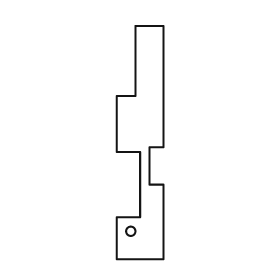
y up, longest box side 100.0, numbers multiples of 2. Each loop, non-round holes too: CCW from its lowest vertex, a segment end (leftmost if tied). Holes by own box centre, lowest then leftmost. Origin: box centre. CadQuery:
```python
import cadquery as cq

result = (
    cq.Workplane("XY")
    .moveTo(-10.0, -50.0)
    .lineTo(10.0, -50.0)
    .lineTo(10.0, -18.0)
    .lineTo(4.0, -18.0)
    .lineTo(4.0, -2.0)
    .lineTo(10.0, -2.0)
    .lineTo(10.0, 50.0)
    .lineTo(-2.0, 50.0)
    .lineTo(-2.0, 20.0)
    .lineTo(-10.0, 20.0)
    .lineTo(-10.0, -4.0)
    .lineTo(0.0, -4.0)
    .lineTo(0.0, -32.0)
    .lineTo(-10.0, -32.0)
    .close()
    .moveTo(-4.0, -38.0)
    .circle(2.0)
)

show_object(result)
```